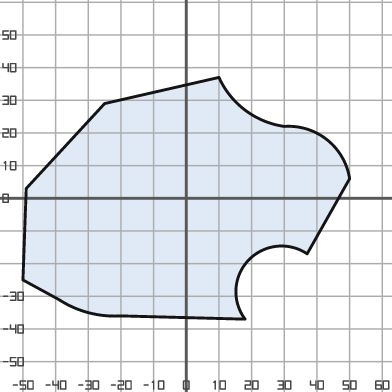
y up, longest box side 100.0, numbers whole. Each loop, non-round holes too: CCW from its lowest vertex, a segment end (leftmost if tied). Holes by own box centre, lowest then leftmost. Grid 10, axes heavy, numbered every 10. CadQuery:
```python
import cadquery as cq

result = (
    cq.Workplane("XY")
    .moveTo(18.0, -37.0)
    .threePointArc((19.0, -19.0), (37.0, -17.0))
    .lineTo(50.0, 6.0)
    .threePointArc((43.0, 18.0), (30.0, 22.0))
    .threePointArc((18.0, 27.0), (10.0, 37.0))
    .lineTo(-25.0, 29.0)
    .lineTo(-49.0, 3.0)
    .lineTo(-50.0, -25.0)
    .lineTo(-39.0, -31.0)
    .threePointArc((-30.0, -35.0), (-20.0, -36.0))
    .close()
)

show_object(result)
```